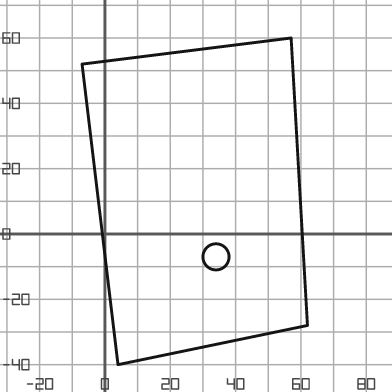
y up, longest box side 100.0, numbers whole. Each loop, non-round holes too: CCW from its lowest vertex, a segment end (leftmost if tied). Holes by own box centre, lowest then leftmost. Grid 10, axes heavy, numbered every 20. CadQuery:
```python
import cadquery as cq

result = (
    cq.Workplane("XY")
    .moveTo(4.0, -40.0)
    .lineTo(62.0, -28.0)
    .lineTo(57.0, 60.0)
    .lineTo(-7.0, 52.0)
    .close()
    .moveTo(34.0, -7.0)
    .circle(4.0)
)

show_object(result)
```